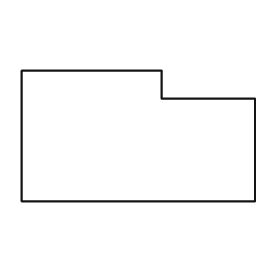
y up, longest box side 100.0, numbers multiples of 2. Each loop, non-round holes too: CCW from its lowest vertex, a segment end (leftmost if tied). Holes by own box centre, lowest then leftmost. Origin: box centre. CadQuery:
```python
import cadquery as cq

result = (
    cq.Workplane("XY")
    .moveTo(-50.0, -28.0)
    .lineTo(50.0, -28.0)
    .lineTo(50.0, 16.0)
    .lineTo(10.0, 16.0)
    .lineTo(10.0, 28.0)
    .lineTo(-50.0, 28.0)
    .close()
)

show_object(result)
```